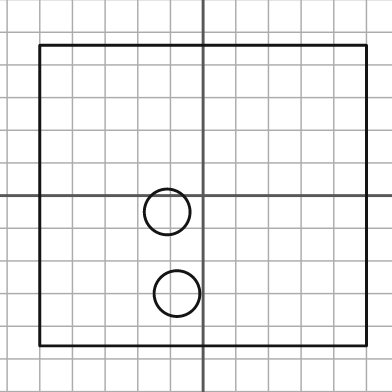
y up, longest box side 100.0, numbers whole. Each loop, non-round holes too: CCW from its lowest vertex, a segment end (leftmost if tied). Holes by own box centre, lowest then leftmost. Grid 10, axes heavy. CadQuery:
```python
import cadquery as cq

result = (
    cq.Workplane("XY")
    .moveTo(-50.0, -46.0)
    .lineTo(50.0, -46.0)
    .lineTo(50.0, 46.0)
    .lineTo(-50.0, 46.0)
    .close()
    .moveTo(-8.0, -30.0)
    .circle(7.0)
    .moveTo(-11.0, -5.0)
    .circle(7.0)
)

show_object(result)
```